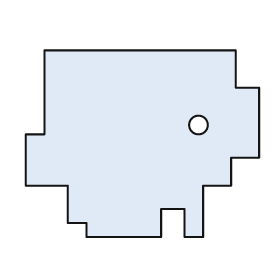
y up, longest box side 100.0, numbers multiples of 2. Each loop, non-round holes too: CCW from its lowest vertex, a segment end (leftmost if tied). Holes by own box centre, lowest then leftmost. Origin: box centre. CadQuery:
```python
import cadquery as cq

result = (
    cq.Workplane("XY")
    .moveTo(-24.0, -40.0)
    .lineTo(8.0, -40.0)
    .lineTo(8.0, -28.0)
    .lineTo(18.0, -28.0)
    .lineTo(18.0, -40.0)
    .lineTo(26.0, -40.0)
    .lineTo(26.0, -18.0)
    .lineTo(38.0, -18.0)
    .lineTo(38.0, -6.0)
    .lineTo(50.0, -6.0)
    .lineTo(50.0, 24.0)
    .lineTo(40.0, 24.0)
    .lineTo(40.0, 40.0)
    .lineTo(-42.0, 40.0)
    .lineTo(-42.0, 4.0)
    .lineTo(-50.0, 4.0)
    .lineTo(-50.0, -18.0)
    .lineTo(-32.0, -18.0)
    .lineTo(-32.0, -34.0)
    .lineTo(-24.0, -34.0)
    .close()
    .moveTo(24.0, 8.0)
    .circle(4.0)
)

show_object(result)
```